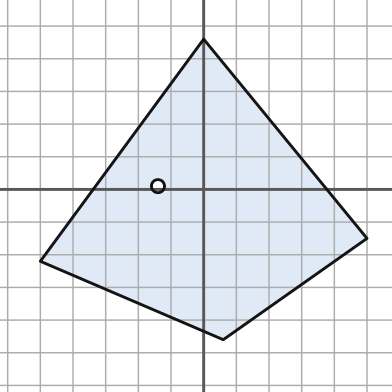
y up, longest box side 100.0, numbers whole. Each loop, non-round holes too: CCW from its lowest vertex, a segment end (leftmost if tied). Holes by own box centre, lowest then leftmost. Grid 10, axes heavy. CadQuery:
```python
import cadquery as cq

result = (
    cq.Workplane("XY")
    .moveTo(6.0, -46.0)
    .lineTo(50.0, -15.0)
    .lineTo(0.0, 46.0)
    .lineTo(-50.0, -22.0)
    .close()
    .moveTo(-14.0, 1.0)
    .circle(2.0)
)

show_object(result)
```